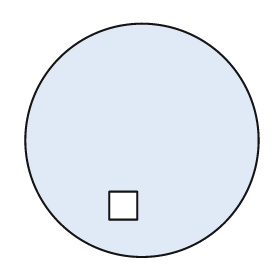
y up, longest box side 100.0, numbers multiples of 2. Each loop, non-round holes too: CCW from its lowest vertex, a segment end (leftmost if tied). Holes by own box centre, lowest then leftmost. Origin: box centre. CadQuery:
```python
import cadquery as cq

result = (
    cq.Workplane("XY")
    .moveTo(0.0, 0.0)
    .circle(50.0)
    .moveTo(-14.0, -34.0)
    .lineTo(-2.0, -34.0)
    .lineTo(-2.0, -22.0)
    .lineTo(-14.0, -22.0)
    .close()
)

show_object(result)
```